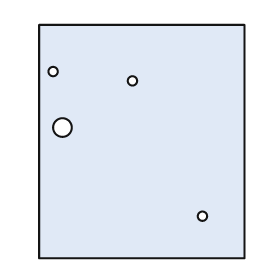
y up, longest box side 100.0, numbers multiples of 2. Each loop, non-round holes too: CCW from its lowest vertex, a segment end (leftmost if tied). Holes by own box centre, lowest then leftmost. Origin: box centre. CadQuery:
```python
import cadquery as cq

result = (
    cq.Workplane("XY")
    .moveTo(-44.0, -50.0)
    .lineTo(44.0, -50.0)
    .lineTo(44.0, 50.0)
    .lineTo(-44.0, 50.0)
    .close()
    .moveTo(26.0, -32.0)
    .circle(2.0)
    .moveTo(-34.0, 6.0)
    .circle(4.0)
    .moveTo(-4.0, 26.0)
    .circle(2.0)
    .moveTo(-38.0, 30.0)
    .circle(2.0)
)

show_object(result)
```